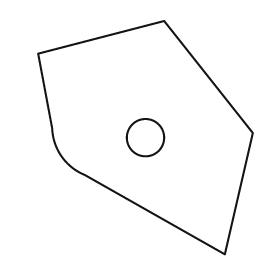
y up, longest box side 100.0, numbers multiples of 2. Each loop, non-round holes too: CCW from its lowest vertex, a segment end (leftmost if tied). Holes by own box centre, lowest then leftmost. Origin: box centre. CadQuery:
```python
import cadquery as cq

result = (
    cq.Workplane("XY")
    .moveTo(34.0, -50.0)
    .lineTo(46.0, 2.0)
    .lineTo(8.0, 50.0)
    .lineTo(-46.0, 36.0)
    .lineTo(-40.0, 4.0)
    .threePointArc((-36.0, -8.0), (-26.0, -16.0))
    .close()
    .moveTo(0.0, 0.0)
    .circle(8.0)
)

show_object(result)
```